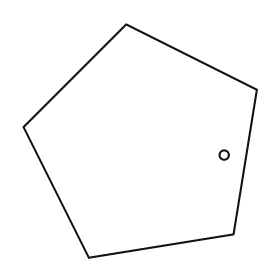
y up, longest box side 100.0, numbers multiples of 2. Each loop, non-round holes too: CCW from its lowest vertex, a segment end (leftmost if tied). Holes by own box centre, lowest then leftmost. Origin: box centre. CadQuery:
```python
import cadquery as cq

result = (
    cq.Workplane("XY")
    .moveTo(-22.0, -50.0)
    .lineTo(40.0, -40.0)
    .lineTo(50.0, 22.0)
    .lineTo(-6.0, 50.0)
    .lineTo(-50.0, 6.0)
    .close()
    .moveTo(36.0, -6.0)
    .circle(2.0)
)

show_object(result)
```